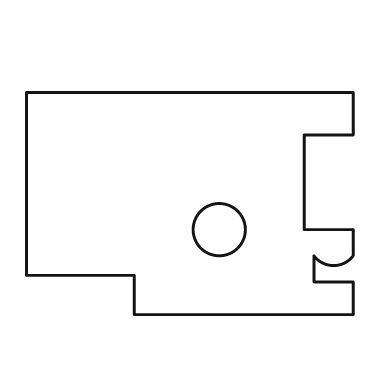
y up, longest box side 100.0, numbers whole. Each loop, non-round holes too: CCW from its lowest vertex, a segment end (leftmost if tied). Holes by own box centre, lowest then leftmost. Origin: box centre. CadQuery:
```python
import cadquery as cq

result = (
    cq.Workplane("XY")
    .moveTo(-17.0, -34.0)
    .lineTo(50.0, -34.0)
    .lineTo(50.0, -24.0)
    .lineTo(38.0, -24.0)
    .lineTo(38.0, -16.0)
    .threePointArc((44.0, -19.0), (50.0, -16.0))
    .lineTo(50.0, -8.0)
    .lineTo(35.0, -8.0)
    .lineTo(35.0, 21.0)
    .lineTo(50.0, 21.0)
    .lineTo(50.0, 34.0)
    .lineTo(-50.0, 34.0)
    .lineTo(-50.0, -22.0)
    .lineTo(-17.0, -22.0)
    .close()
    .moveTo(9.0, -8.0)
    .circle(8.0)
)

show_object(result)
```